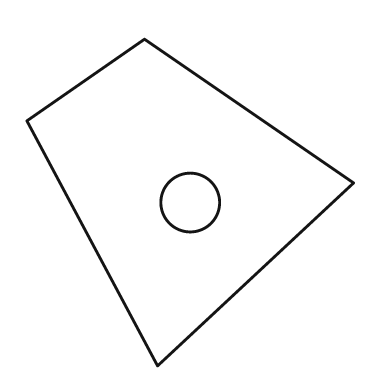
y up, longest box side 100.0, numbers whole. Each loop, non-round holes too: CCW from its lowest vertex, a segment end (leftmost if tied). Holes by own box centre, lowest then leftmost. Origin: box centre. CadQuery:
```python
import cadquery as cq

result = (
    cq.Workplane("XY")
    .moveTo(-10.0, -50.0)
    .lineTo(50.0, 6.0)
    .lineTo(-14.0, 50.0)
    .lineTo(-50.0, 25.0)
    .close()
    .moveTo(0.0, 0.0)
    .circle(9.0)
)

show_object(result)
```